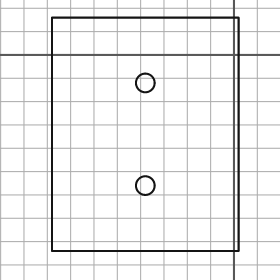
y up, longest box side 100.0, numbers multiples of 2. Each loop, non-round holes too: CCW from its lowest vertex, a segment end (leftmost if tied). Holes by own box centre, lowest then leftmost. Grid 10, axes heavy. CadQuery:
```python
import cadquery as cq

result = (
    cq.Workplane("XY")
    .moveTo(-78.0, -84.0)
    .lineTo(2.0, -84.0)
    .lineTo(2.0, 16.0)
    .lineTo(-78.0, 16.0)
    .close()
    .moveTo(-38.0, -56.0)
    .circle(4.0)
    .moveTo(-38.0, -12.0)
    .circle(4.0)
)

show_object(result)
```